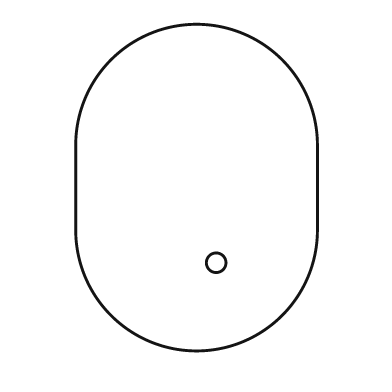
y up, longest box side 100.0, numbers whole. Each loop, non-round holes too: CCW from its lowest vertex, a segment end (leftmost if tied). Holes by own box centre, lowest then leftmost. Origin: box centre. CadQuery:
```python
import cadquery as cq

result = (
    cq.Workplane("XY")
    .moveTo(-37.0, -13.0)
    .threePointArc((0.0, -50.0), (37.0, -13.0))
    .lineTo(37.0, 13.0)
    .threePointArc((0.0, 50.0), (-37.0, 13.0))
    .close()
    .moveTo(6.0, -23.0)
    .circle(3.0)
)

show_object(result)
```